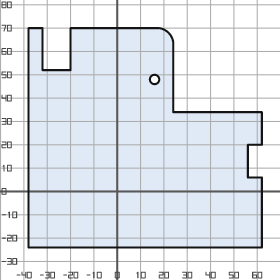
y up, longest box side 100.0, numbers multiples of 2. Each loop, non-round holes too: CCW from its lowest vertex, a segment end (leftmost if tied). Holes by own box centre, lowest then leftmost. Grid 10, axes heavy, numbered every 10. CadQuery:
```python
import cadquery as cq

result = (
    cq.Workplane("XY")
    .moveTo(-38.0, -24.0)
    .lineTo(62.0, -24.0)
    .lineTo(62.0, 6.0)
    .lineTo(56.0, 6.0)
    .lineTo(56.0, 20.0)
    .lineTo(62.0, 20.0)
    .lineTo(62.0, 34.0)
    .lineTo(24.0, 34.0)
    .lineTo(24.0, 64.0)
    .threePointArc((22.0, 68.0), (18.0, 70.0))
    .lineTo(-20.0, 70.0)
    .lineTo(-20.0, 52.0)
    .lineTo(-32.0, 52.0)
    .lineTo(-32.0, 70.0)
    .lineTo(-38.0, 70.0)
    .close()
    .moveTo(16.0, 48.0)
    .circle(2.0)
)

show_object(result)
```